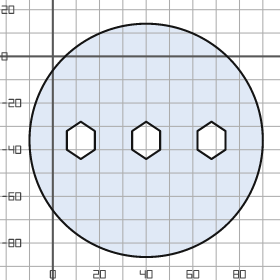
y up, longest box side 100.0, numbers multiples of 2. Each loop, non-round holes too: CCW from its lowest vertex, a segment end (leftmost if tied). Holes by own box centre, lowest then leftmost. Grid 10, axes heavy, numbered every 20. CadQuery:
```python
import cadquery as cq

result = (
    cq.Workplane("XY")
    .moveTo(40.0, -36.0)
    .circle(50.0)
    .moveTo(12.0, -44.0)
    .lineTo(18.0, -40.0)
    .lineTo(18.0, -32.0)
    .lineTo(12.0, -28.0)
    .lineTo(6.0, -32.0)
    .lineTo(6.0, -40.0)
    .close()
    .moveTo(40.0, -44.0)
    .lineTo(46.0, -40.0)
    .lineTo(46.0, -32.0)
    .lineTo(40.0, -28.0)
    .lineTo(34.0, -32.0)
    .lineTo(34.0, -40.0)
    .close()
    .moveTo(68.0, -44.0)
    .lineTo(74.0, -40.0)
    .lineTo(74.0, -32.0)
    .lineTo(68.0, -28.0)
    .lineTo(62.0, -32.0)
    .lineTo(62.0, -40.0)
    .close()
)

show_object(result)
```